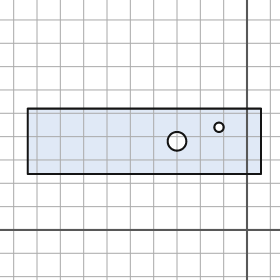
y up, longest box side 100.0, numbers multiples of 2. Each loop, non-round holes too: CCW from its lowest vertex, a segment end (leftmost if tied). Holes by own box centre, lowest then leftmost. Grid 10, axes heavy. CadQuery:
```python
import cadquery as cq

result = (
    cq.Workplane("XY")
    .moveTo(-94.0, 24.0)
    .lineTo(6.0, 24.0)
    .lineTo(6.0, 52.0)
    .lineTo(-94.0, 52.0)
    .close()
    .moveTo(-30.0, 38.0)
    .circle(4.0)
    .moveTo(-12.0, 44.0)
    .circle(2.0)
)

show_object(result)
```